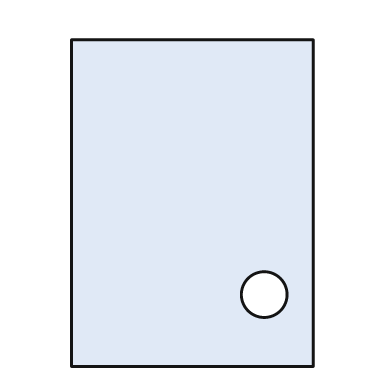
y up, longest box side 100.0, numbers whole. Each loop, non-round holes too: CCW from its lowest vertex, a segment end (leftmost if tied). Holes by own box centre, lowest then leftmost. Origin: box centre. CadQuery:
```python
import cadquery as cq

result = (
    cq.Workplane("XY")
    .moveTo(-37.0, -50.0)
    .lineTo(37.0, -50.0)
    .lineTo(37.0, 50.0)
    .lineTo(-37.0, 50.0)
    .close()
    .moveTo(22.0, -28.0)
    .circle(7.0)
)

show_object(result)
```